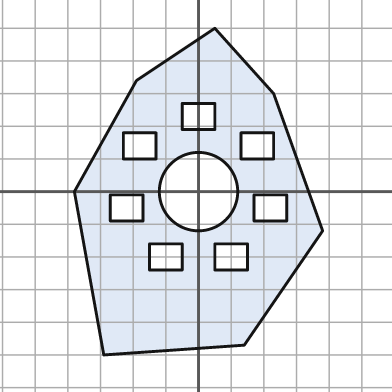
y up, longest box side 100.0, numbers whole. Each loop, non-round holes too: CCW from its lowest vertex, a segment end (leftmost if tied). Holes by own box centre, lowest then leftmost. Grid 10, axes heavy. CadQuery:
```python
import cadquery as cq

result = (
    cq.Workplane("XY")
    .moveTo(-29.0, -50.0)
    .lineTo(14.0, -47.0)
    .lineTo(38.0, -12.0)
    .lineTo(23.0, 30.0)
    .lineTo(5.0, 50.0)
    .lineTo(-19.0, 34.0)
    .lineTo(-38.0, 0.0)
    .close()
    .moveTo(-15.0, -24.0)
    .lineTo(-5.0, -24.0)
    .lineTo(-5.0, -16.0)
    .lineTo(-15.0, -16.0)
    .close()
    .moveTo(5.0, -24.0)
    .lineTo(15.0, -24.0)
    .lineTo(15.0, -16.0)
    .lineTo(5.0, -16.0)
    .close()
    .moveTo(-27.0, -9.0)
    .lineTo(-17.0, -9.0)
    .lineTo(-17.0, -1.0)
    .lineTo(-27.0, -1.0)
    .close()
    .moveTo(17.0, -9.0)
    .lineTo(27.0, -9.0)
    .lineTo(27.0, -1.0)
    .lineTo(17.0, -1.0)
    .close()
    .moveTo(0.0, 0.0)
    .circle(12.0)
    .moveTo(-23.0, 10.0)
    .lineTo(-13.0, 10.0)
    .lineTo(-13.0, 18.0)
    .lineTo(-23.0, 18.0)
    .close()
    .moveTo(13.0, 10.0)
    .lineTo(23.0, 10.0)
    .lineTo(23.0, 18.0)
    .lineTo(13.0, 18.0)
    .close()
    .moveTo(-5.0, 19.0)
    .lineTo(5.0, 19.0)
    .lineTo(5.0, 27.0)
    .lineTo(-5.0, 27.0)
    .close()
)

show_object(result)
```